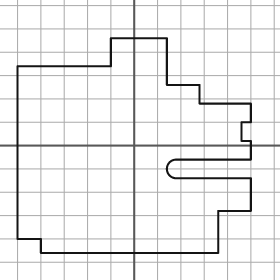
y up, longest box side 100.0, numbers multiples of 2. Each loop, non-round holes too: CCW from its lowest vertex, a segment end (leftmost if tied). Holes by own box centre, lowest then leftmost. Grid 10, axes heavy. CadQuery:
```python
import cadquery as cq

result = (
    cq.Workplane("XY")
    .moveTo(-40.0, -46.0)
    .lineTo(36.0, -46.0)
    .lineTo(36.0, -28.0)
    .lineTo(50.0, -28.0)
    .lineTo(50.0, -14.0)
    .lineTo(18.0, -14.0)
    .threePointArc((14.0, -10.0), (18.0, -6.0))
    .lineTo(50.0, -6.0)
    .lineTo(50.0, 2.0)
    .lineTo(46.0, 2.0)
    .lineTo(46.0, 10.0)
    .lineTo(50.0, 10.0)
    .lineTo(50.0, 18.0)
    .lineTo(28.0, 18.0)
    .lineTo(28.0, 26.0)
    .lineTo(14.0, 26.0)
    .lineTo(14.0, 46.0)
    .lineTo(-10.0, 46.0)
    .lineTo(-10.0, 34.0)
    .lineTo(-50.0, 34.0)
    .lineTo(-50.0, -40.0)
    .lineTo(-40.0, -40.0)
    .close()
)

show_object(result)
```